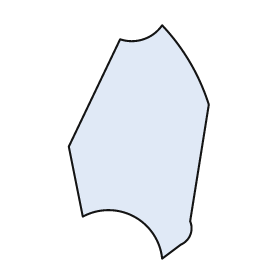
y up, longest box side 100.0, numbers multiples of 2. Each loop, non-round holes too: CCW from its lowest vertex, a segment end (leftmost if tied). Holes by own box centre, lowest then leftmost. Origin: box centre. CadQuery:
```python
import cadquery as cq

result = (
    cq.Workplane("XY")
    .moveTo(10.0, -50.0)
    .lineTo(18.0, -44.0)
    .threePointArc((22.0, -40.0), (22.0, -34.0))
    .lineTo(30.0, 16.0)
    .threePointArc((22.0, 34.0), (10.0, 50.0))
    .threePointArc((2.0, 44.0), (-8.0, 44.0))
    .lineTo(-30.0, -2.0)
    .lineTo(-24.0, -32.0)
    .threePointArc((-2.0, -32.0), (10.0, -50.0))
    .close()
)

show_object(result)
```